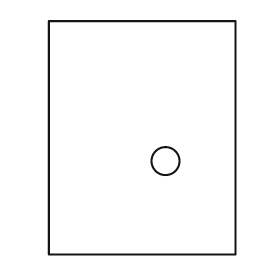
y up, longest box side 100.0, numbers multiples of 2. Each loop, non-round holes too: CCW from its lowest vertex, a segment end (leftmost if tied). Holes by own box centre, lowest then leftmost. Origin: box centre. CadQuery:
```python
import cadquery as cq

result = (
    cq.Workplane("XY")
    .moveTo(-40.0, -50.0)
    .lineTo(40.0, -50.0)
    .lineTo(40.0, 50.0)
    .lineTo(-40.0, 50.0)
    .close()
    .moveTo(10.0, -10.0)
    .circle(6.0)
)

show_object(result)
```